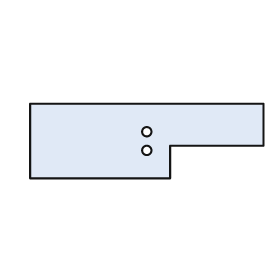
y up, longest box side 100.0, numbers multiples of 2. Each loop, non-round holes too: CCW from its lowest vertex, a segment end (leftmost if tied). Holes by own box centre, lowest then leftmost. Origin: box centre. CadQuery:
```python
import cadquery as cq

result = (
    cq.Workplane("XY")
    .moveTo(-50.0, -16.0)
    .lineTo(10.0, -16.0)
    .lineTo(10.0, -2.0)
    .lineTo(50.0, -2.0)
    .lineTo(50.0, 16.0)
    .lineTo(-50.0, 16.0)
    .close()
    .moveTo(0.0, -4.0)
    .circle(2.0)
    .moveTo(0.0, 4.0)
    .circle(2.0)
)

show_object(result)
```